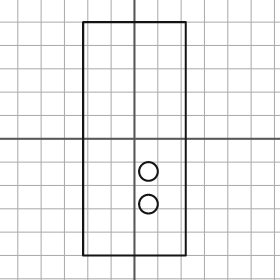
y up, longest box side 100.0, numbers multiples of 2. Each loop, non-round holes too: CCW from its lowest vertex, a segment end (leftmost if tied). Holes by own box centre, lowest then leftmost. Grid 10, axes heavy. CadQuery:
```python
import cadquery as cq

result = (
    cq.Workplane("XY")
    .moveTo(-22.0, -50.0)
    .lineTo(22.0, -50.0)
    .lineTo(22.0, 50.0)
    .lineTo(-22.0, 50.0)
    .close()
    .moveTo(6.0, -28.0)
    .circle(4.0)
    .moveTo(6.0, -14.0)
    .circle(4.0)
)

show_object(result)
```